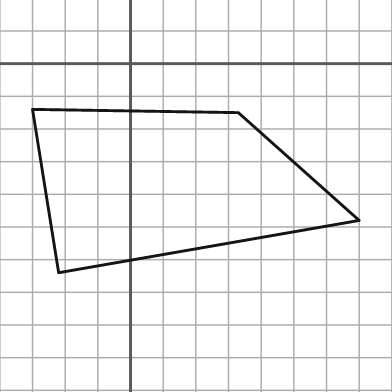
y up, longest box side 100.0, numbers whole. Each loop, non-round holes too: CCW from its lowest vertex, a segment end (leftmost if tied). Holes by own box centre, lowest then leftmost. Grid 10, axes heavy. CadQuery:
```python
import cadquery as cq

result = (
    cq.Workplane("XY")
    .moveTo(-22.0, -64.0)
    .lineTo(70.0, -48.0)
    .lineTo(33.0, -15.0)
    .lineTo(-30.0, -14.0)
    .close()
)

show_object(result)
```